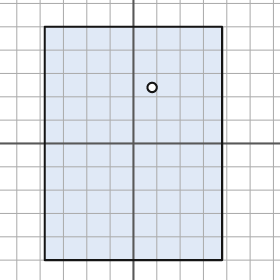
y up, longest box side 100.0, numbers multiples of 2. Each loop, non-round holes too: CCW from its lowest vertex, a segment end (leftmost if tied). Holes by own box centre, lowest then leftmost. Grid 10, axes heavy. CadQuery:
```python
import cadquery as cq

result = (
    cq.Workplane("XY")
    .moveTo(-38.0, -50.0)
    .lineTo(38.0, -50.0)
    .lineTo(38.0, 50.0)
    .lineTo(-38.0, 50.0)
    .close()
    .moveTo(8.0, 24.0)
    .circle(2.0)
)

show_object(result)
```